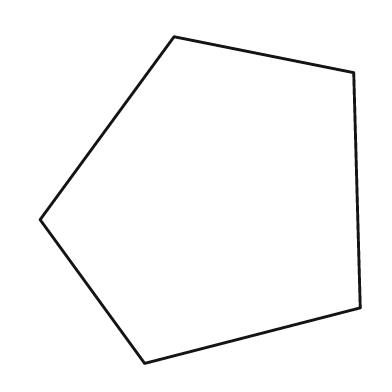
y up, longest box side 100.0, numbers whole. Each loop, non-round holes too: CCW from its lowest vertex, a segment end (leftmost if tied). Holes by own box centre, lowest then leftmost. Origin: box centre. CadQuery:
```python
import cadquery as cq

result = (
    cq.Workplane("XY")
    .moveTo(-17.0, -50.0)
    .lineTo(49.0, -33.0)
    .lineTo(47.0, 39.0)
    .lineTo(-8.0, 50.0)
    .lineTo(-49.0, -6.0)
    .close()
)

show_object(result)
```